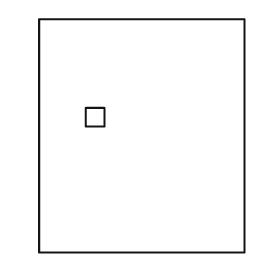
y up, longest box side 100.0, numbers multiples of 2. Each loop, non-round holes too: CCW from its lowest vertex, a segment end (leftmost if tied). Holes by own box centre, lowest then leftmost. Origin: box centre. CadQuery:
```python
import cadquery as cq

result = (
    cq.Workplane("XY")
    .moveTo(-44.0, -50.0)
    .lineTo(44.0, -50.0)
    .lineTo(44.0, 50.0)
    .lineTo(-44.0, 50.0)
    .close()
    .moveTo(-24.0, 4.0)
    .lineTo(-16.0, 4.0)
    .lineTo(-16.0, 12.0)
    .lineTo(-24.0, 12.0)
    .close()
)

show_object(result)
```